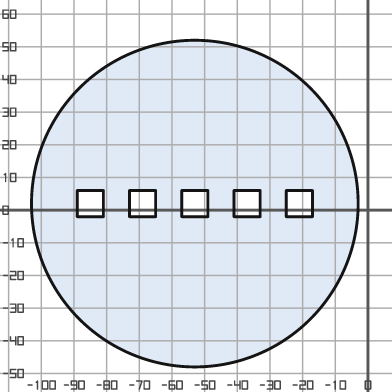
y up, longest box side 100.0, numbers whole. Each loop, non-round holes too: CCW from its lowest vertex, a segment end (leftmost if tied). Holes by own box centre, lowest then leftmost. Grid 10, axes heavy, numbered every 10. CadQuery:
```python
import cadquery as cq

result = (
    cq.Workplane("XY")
    .moveTo(-53.0, 2.0)
    .circle(50.0)
    .moveTo(-89.0, -2.0)
    .lineTo(-81.0, -2.0)
    .lineTo(-81.0, 6.0)
    .lineTo(-89.0, 6.0)
    .close()
    .moveTo(-73.0, -2.0)
    .lineTo(-65.0, -2.0)
    .lineTo(-65.0, 6.0)
    .lineTo(-73.0, 6.0)
    .close()
    .moveTo(-57.0, -2.0)
    .lineTo(-49.0, -2.0)
    .lineTo(-49.0, 6.0)
    .lineTo(-57.0, 6.0)
    .close()
    .moveTo(-41.0, -2.0)
    .lineTo(-33.0, -2.0)
    .lineTo(-33.0, 6.0)
    .lineTo(-41.0, 6.0)
    .close()
    .moveTo(-25.0, -2.0)
    .lineTo(-17.0, -2.0)
    .lineTo(-17.0, 6.0)
    .lineTo(-25.0, 6.0)
    .close()
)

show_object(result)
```